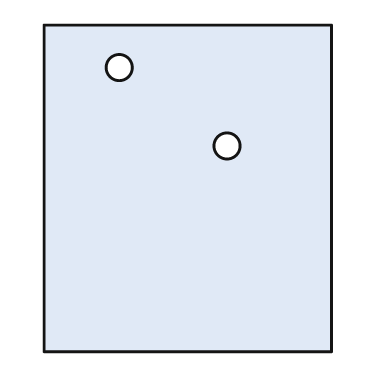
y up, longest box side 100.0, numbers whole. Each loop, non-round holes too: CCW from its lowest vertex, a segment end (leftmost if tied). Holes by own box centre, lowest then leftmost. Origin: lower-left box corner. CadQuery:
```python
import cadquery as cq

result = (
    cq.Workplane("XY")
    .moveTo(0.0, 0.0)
    .lineTo(88.0, 0.0)
    .lineTo(88.0, 100.0)
    .lineTo(0.0, 100.0)
    .close()
    .moveTo(56.0, 63.0)
    .circle(4.0)
    .moveTo(23.0, 87.0)
    .circle(4.0)
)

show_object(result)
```